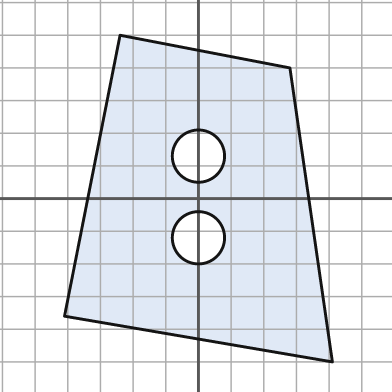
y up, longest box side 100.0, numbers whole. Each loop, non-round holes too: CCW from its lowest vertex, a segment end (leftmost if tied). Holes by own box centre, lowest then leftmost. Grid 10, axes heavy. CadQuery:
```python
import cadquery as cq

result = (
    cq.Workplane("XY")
    .moveTo(41.0, -50.0)
    .lineTo(28.0, 40.0)
    .lineTo(-24.0, 50.0)
    .lineTo(-41.0, -36.0)
    .close()
    .moveTo(0.0, -12.0)
    .circle(8.0)
    .moveTo(0.0, 13.0)
    .circle(8.0)
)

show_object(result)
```